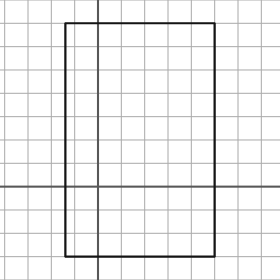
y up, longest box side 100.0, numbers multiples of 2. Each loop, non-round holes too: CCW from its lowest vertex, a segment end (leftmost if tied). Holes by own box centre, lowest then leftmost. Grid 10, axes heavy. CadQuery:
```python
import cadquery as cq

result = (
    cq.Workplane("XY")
    .moveTo(-14.0, -30.0)
    .lineTo(50.0, -30.0)
    .lineTo(50.0, 70.0)
    .lineTo(-14.0, 70.0)
    .close()
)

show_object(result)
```